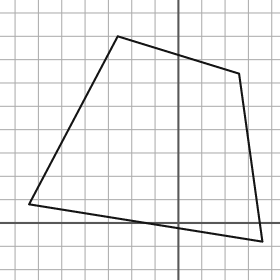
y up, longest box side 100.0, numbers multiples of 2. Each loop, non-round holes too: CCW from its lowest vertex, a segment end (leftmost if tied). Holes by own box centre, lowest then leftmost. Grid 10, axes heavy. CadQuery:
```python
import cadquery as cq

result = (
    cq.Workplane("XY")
    .moveTo(36.0, -8.0)
    .lineTo(26.0, 64.0)
    .lineTo(-26.0, 80.0)
    .lineTo(-64.0, 8.0)
    .close()
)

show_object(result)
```